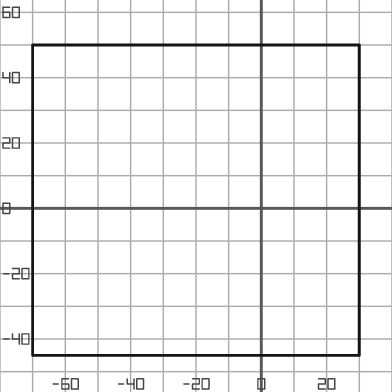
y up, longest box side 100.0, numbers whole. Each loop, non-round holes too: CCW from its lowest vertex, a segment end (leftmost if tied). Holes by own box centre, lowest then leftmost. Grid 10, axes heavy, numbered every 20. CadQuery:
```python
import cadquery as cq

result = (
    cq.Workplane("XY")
    .moveTo(-70.0, -45.0)
    .lineTo(30.0, -45.0)
    .lineTo(30.0, 50.0)
    .lineTo(-70.0, 50.0)
    .close()
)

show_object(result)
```